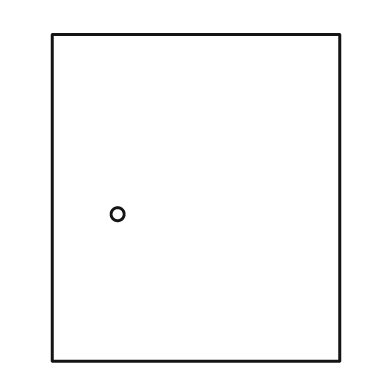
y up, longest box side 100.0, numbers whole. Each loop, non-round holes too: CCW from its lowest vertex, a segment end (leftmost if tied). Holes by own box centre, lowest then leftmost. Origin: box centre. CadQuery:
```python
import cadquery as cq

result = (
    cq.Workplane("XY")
    .moveTo(-44.0, -50.0)
    .lineTo(44.0, -50.0)
    .lineTo(44.0, 50.0)
    .lineTo(-44.0, 50.0)
    .close()
    .moveTo(-24.0, -5.0)
    .circle(2.0)
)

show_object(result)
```